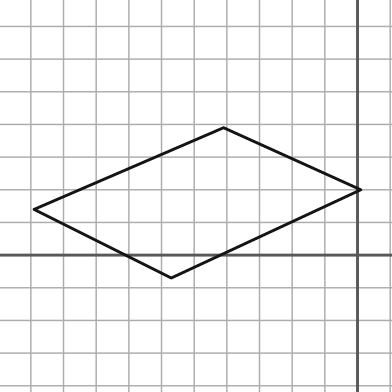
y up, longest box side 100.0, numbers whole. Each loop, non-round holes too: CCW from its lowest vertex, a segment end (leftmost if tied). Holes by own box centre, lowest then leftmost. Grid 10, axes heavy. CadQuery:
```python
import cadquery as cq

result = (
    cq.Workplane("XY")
    .moveTo(-57.0, -7.0)
    .lineTo(1.0, 20.0)
    .lineTo(-41.0, 39.0)
    .lineTo(-99.0, 14.0)
    .close()
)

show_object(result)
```